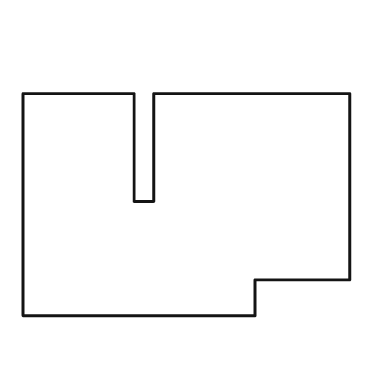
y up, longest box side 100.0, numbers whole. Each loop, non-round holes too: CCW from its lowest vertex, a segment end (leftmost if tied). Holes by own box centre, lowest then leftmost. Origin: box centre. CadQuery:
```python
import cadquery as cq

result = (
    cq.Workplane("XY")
    .moveTo(-50.0, -34.0)
    .lineTo(21.0, -34.0)
    .lineTo(21.0, -23.0)
    .lineTo(50.0, -23.0)
    .lineTo(50.0, 34.0)
    .lineTo(-10.0, 34.0)
    .lineTo(-10.0, 1.0)
    .lineTo(-16.0, 1.0)
    .lineTo(-16.0, 34.0)
    .lineTo(-50.0, 34.0)
    .close()
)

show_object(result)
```